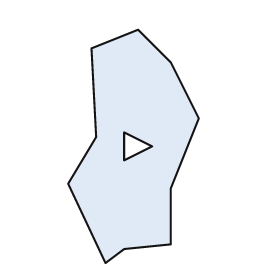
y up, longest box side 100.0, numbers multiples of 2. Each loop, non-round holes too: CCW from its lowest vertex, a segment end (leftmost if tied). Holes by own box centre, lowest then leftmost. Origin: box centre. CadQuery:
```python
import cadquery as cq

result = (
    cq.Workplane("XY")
    .moveTo(-12.0, -50.0)
    .lineTo(-4.0, -44.0)
    .lineTo(16.0, -42.0)
    .lineTo(16.0, -18.0)
    .lineTo(28.0, 12.0)
    .lineTo(16.0, 36.0)
    .lineTo(2.0, 50.0)
    .lineTo(-18.0, 42.0)
    .lineTo(-16.0, 4.0)
    .lineTo(-28.0, -16.0)
    .close()
    .moveTo(-4.0, -6.0)
    .lineTo(8.0, 0.0)
    .lineTo(-4.0, 6.0)
    .close()
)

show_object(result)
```